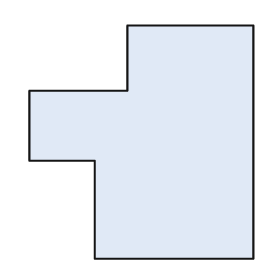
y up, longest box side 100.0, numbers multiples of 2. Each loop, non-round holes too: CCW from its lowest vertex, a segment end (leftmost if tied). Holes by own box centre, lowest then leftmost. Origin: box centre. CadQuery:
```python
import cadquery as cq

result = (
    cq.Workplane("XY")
    .moveTo(-20.0, -50.0)
    .lineTo(48.0, -50.0)
    .lineTo(48.0, 50.0)
    .lineTo(-6.0, 50.0)
    .lineTo(-6.0, 22.0)
    .lineTo(-48.0, 22.0)
    .lineTo(-48.0, -8.0)
    .lineTo(-20.0, -8.0)
    .close()
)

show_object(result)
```